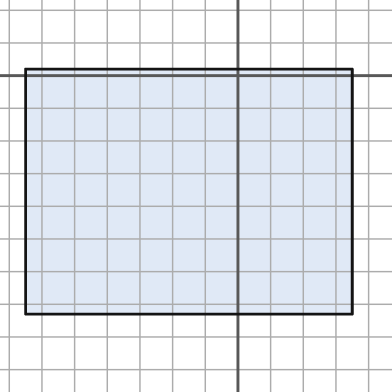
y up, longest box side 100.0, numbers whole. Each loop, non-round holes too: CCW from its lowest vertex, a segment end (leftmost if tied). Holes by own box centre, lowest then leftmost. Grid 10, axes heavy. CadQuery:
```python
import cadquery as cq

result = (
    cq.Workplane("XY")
    .moveTo(-65.0, -73.0)
    .lineTo(35.0, -73.0)
    .lineTo(35.0, 2.0)
    .lineTo(-65.0, 2.0)
    .close()
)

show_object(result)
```